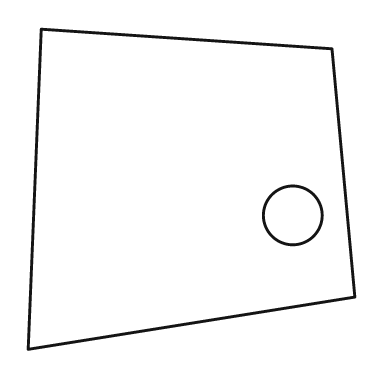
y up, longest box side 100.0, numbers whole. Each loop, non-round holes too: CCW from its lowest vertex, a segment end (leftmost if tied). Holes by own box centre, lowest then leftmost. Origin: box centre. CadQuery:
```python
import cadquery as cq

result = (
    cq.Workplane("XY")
    .moveTo(-50.0, -49.0)
    .lineTo(50.0, -33.0)
    .lineTo(43.0, 43.0)
    .lineTo(-46.0, 49.0)
    .close()
    .moveTo(31.0, -8.0)
    .circle(9.0)
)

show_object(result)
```